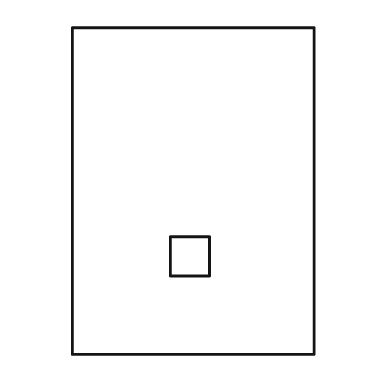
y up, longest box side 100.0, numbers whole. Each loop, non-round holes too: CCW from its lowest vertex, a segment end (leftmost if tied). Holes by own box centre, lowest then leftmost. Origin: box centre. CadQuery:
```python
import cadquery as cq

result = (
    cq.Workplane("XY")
    .moveTo(-37.0, -50.0)
    .lineTo(37.0, -50.0)
    .lineTo(37.0, 50.0)
    .lineTo(-37.0, 50.0)
    .close()
    .moveTo(-7.0, -26.0)
    .lineTo(5.0, -26.0)
    .lineTo(5.0, -14.0)
    .lineTo(-7.0, -14.0)
    .close()
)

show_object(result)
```